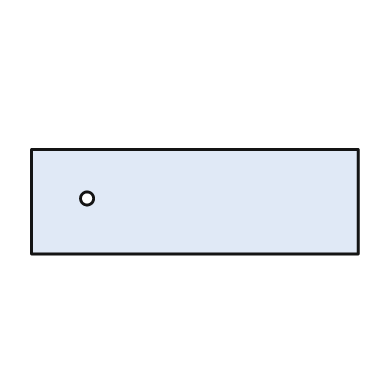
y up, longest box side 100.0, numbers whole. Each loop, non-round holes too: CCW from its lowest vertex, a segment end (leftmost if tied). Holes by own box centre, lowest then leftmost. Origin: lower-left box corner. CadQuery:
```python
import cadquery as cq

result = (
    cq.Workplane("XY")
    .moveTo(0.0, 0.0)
    .lineTo(100.0, 0.0)
    .lineTo(100.0, 32.0)
    .lineTo(0.0, 32.0)
    .close()
    .moveTo(17.0, 17.0)
    .circle(2.0)
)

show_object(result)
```